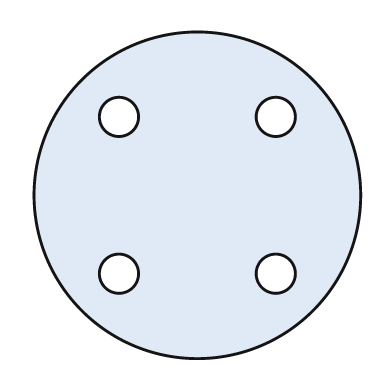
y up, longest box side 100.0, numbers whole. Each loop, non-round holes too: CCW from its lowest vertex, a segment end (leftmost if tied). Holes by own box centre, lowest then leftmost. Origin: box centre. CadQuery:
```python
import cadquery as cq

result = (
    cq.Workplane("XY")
    .moveTo(0.0, 0.0)
    .circle(50.0)
    .moveTo(-24.0, -24.0)
    .circle(6.0)
    .moveTo(24.0, -24.0)
    .circle(6.0)
    .moveTo(-24.0, 24.0)
    .circle(6.0)
    .moveTo(24.0, 24.0)
    .circle(6.0)
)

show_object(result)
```